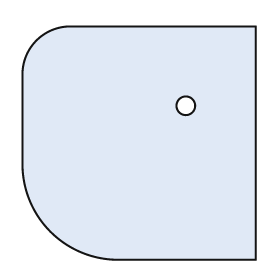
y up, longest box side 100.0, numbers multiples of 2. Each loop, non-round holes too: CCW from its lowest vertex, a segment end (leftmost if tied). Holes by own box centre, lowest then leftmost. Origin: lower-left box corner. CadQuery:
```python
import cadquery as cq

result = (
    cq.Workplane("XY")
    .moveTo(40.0, 0.0)
    .lineTo(100.0, 0.0)
    .lineTo(100.0, 100.0)
    .lineTo(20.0, 100.0)
    .threePointArc((6.0, 94.0), (0.0, 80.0))
    .lineTo(0.0, 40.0)
    .threePointArc((12.0, 12.0), (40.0, 0.0))
    .close()
    .moveTo(70.0, 66.0)
    .circle(4.0)
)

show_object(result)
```